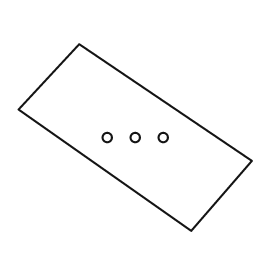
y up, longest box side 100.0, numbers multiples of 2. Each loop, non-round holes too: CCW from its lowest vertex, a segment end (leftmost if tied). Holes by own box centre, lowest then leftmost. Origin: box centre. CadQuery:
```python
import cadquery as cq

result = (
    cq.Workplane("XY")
    .moveTo(24.0, -40.0)
    .lineTo(50.0, -10.0)
    .lineTo(-24.0, 40.0)
    .lineTo(-50.0, 12.0)
    .close()
    .moveTo(-12.0, 0.0)
    .circle(2.0)
    .moveTo(0.0, 0.0)
    .circle(2.0)
    .moveTo(12.0, 0.0)
    .circle(2.0)
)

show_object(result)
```